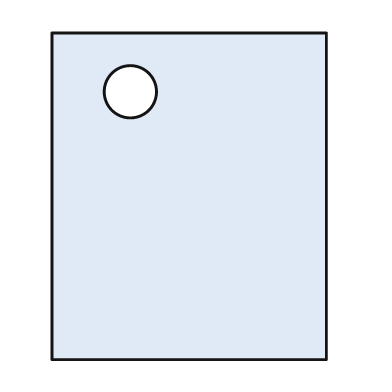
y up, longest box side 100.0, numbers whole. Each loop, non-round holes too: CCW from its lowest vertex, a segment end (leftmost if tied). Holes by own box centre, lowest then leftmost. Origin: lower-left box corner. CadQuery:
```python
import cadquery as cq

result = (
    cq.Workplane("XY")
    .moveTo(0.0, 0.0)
    .lineTo(84.0, 0.0)
    .lineTo(84.0, 100.0)
    .lineTo(0.0, 100.0)
    .close()
    .moveTo(24.0, 82.0)
    .circle(8.0)
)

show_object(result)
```